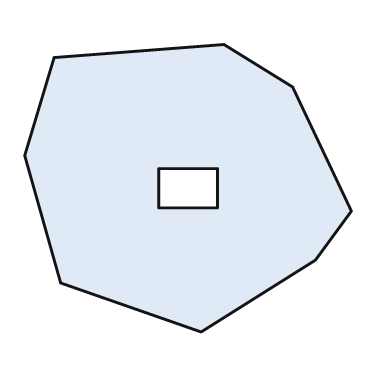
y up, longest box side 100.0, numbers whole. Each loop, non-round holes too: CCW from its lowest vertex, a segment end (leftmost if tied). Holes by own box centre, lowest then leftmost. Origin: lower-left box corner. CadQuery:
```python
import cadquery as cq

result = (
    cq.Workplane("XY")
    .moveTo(54.0, 0.0)
    .lineTo(89.0, 22.0)
    .lineTo(100.0, 37.0)
    .lineTo(82.0, 75.0)
    .lineTo(61.0, 88.0)
    .lineTo(9.0, 84.0)
    .lineTo(0.0, 54.0)
    .lineTo(11.0, 15.0)
    .close()
    .moveTo(41.0, 38.0)
    .lineTo(59.0, 38.0)
    .lineTo(59.0, 50.0)
    .lineTo(41.0, 50.0)
    .close()
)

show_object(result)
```